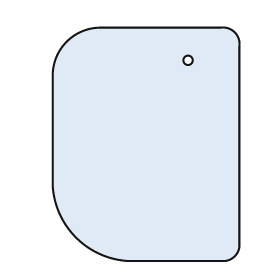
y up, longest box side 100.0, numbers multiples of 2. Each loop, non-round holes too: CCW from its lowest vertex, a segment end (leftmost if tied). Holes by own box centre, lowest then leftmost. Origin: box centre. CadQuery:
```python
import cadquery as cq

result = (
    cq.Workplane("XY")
    .moveTo(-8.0, -50.0)
    .lineTo(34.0, -50.0)
    .threePointArc((38.0, -48.0), (40.0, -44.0))
    .lineTo(40.0, 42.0)
    .threePointArc((38.0, 48.0), (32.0, 50.0))
    .lineTo(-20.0, 50.0)
    .threePointArc((-34.0, 44.0), (-40.0, 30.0))
    .lineTo(-40.0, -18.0)
    .threePointArc((-30.0, -40.0), (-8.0, -50.0))
    .close()
    .moveTo(18.0, 36.0)
    .circle(2.0)
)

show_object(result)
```